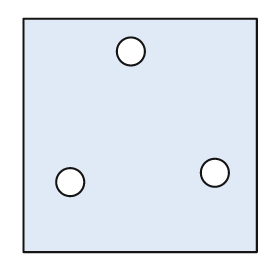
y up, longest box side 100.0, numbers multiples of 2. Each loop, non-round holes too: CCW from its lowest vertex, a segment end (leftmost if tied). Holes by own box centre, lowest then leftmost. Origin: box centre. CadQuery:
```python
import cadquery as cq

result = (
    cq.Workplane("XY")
    .moveTo(-50.0, -50.0)
    .lineTo(50.0, -50.0)
    .lineTo(50.0, 50.0)
    .lineTo(-50.0, 50.0)
    .close()
    .moveTo(-30.0, -20.0)
    .circle(6.0)
    .moveTo(32.0, -16.0)
    .circle(6.0)
    .moveTo(-4.0, 36.0)
    .circle(6.0)
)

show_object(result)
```